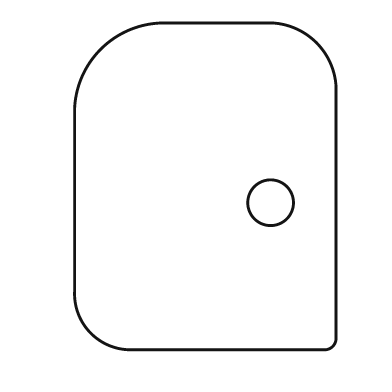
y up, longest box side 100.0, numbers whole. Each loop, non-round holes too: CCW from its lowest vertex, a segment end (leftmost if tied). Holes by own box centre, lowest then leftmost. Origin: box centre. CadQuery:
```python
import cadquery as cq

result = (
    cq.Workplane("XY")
    .moveTo(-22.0, -50.0)
    .lineTo(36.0, -50.0)
    .threePointArc((39.0, -49.0), (40.0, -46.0))
    .lineTo(40.0, 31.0)
    .threePointArc((34.0, 44.0), (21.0, 50.0))
    .lineTo(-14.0, 50.0)
    .threePointArc((-32.0, 42.0), (-40.0, 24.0))
    .lineTo(-40.0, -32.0)
    .threePointArc((-35.0, -45.0), (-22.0, -50.0))
    .close()
    .moveTo(20.0, -5.0)
    .circle(7.0)
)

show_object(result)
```